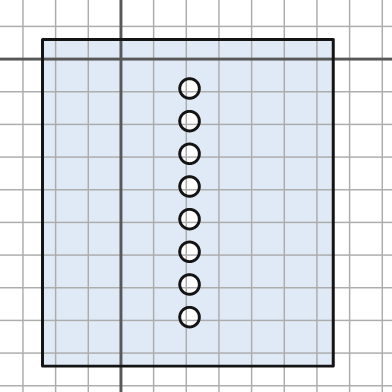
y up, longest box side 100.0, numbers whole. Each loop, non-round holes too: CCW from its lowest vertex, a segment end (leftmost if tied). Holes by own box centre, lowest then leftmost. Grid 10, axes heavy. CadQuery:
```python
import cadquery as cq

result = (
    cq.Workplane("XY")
    .moveTo(-24.0, -94.0)
    .lineTo(65.0, -94.0)
    .lineTo(65.0, 6.0)
    .lineTo(-24.0, 6.0)
    .close()
    .moveTo(21.0, -79.0)
    .circle(3.0)
    .moveTo(21.0, -69.0)
    .circle(3.0)
    .moveTo(21.0, -59.0)
    .circle(3.0)
    .moveTo(21.0, -49.0)
    .circle(3.0)
    .moveTo(21.0, -39.0)
    .circle(3.0)
    .moveTo(21.0, -29.0)
    .circle(3.0)
    .moveTo(21.0, -19.0)
    .circle(3.0)
    .moveTo(21.0, -9.0)
    .circle(3.0)
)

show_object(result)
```